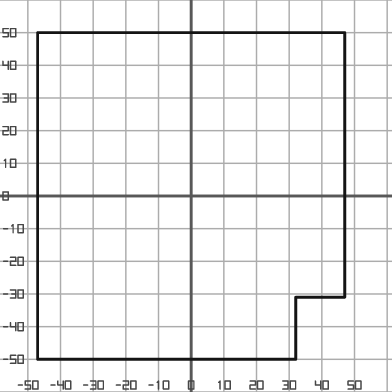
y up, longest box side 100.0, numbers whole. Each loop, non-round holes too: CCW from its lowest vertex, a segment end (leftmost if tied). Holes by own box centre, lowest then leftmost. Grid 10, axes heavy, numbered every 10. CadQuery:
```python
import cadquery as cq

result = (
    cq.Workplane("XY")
    .moveTo(-47.0, -50.0)
    .lineTo(32.0, -50.0)
    .lineTo(32.0, -31.0)
    .lineTo(47.0, -31.0)
    .lineTo(47.0, 50.0)
    .lineTo(-47.0, 50.0)
    .close()
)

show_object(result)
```